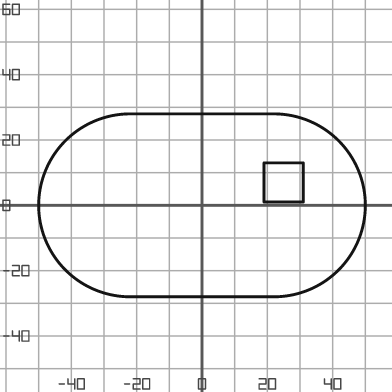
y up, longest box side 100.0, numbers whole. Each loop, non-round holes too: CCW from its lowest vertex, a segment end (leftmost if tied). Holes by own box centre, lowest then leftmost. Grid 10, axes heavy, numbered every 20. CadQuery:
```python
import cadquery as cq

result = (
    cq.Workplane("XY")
    .moveTo(-22.0, -28.0)
    .lineTo(22.0, -28.0)
    .threePointArc((50.0, 0.0), (22.0, 28.0))
    .lineTo(-22.0, 28.0)
    .threePointArc((-50.0, 0.0), (-22.0, -28.0))
    .close()
    .moveTo(19.0, 1.0)
    .lineTo(31.0, 1.0)
    .lineTo(31.0, 13.0)
    .lineTo(19.0, 13.0)
    .close()
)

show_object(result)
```